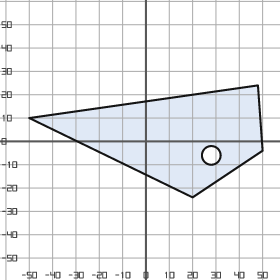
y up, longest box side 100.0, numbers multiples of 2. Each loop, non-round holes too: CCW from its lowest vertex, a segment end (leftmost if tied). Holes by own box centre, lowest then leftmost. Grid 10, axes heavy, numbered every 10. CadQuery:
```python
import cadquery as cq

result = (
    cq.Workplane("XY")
    .moveTo(20.0, -24.0)
    .lineTo(50.0, -4.0)
    .lineTo(48.0, 24.0)
    .lineTo(-50.0, 10.0)
    .close()
    .moveTo(28.0, -6.0)
    .circle(4.0)
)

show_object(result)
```